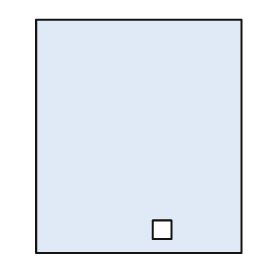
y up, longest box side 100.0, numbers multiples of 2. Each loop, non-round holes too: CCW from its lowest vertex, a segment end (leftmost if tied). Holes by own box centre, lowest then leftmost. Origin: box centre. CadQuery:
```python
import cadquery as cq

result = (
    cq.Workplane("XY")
    .moveTo(-44.0, -50.0)
    .lineTo(44.0, -50.0)
    .lineTo(44.0, 50.0)
    .lineTo(-44.0, 50.0)
    .close()
    .moveTo(6.0, -44.0)
    .lineTo(14.0, -44.0)
    .lineTo(14.0, -36.0)
    .lineTo(6.0, -36.0)
    .close()
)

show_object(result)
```